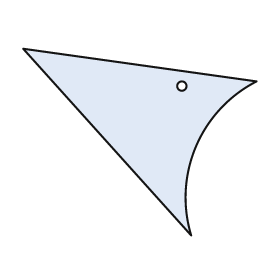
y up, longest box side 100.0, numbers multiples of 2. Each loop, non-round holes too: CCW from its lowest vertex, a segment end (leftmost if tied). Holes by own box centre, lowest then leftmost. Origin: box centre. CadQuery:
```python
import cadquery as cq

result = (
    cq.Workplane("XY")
    .moveTo(22.0, -40.0)
    .threePointArc((24.0, -2.0), (50.0, 26.0))
    .lineTo(-50.0, 40.0)
    .close()
    .moveTo(18.0, 24.0)
    .circle(2.0)
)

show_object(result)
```